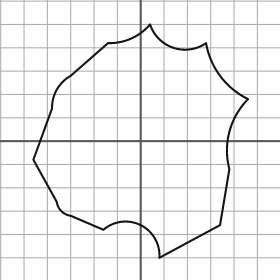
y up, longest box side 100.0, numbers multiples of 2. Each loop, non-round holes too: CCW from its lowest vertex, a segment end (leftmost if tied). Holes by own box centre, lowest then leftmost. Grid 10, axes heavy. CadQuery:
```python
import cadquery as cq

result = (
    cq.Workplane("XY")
    .moveTo(8.0, -50.0)
    .lineTo(34.0, -36.0)
    .lineTo(38.0, -12.0)
    .threePointArc((38.0, 4.0), (46.0, 18.0))
    .threePointArc((34.0, 28.0), (28.0, 42.0))
    .threePointArc((14.0, 40.0), (4.0, 50.0))
    .threePointArc((-4.0, 44.0), (-14.0, 42.0))
    .lineTo(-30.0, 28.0)
    .threePointArc((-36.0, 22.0), (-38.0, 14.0))
    .lineTo(-46.0, -8.0)
    .lineTo(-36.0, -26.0)
    .threePointArc((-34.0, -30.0), (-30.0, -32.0))
    .lineTo(-16.0, -38.0)
    .threePointArc((0.0, -36.0), (8.0, -50.0))
    .close()
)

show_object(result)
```